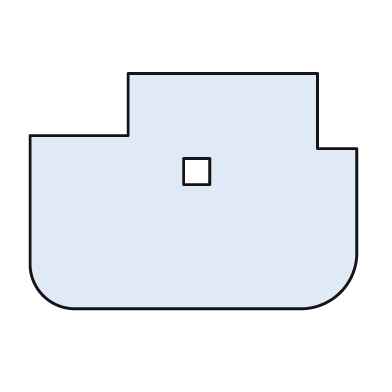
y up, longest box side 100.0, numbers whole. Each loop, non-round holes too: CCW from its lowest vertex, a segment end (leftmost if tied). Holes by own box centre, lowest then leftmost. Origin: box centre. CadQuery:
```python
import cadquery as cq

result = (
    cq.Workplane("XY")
    .moveTo(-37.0, -36.0)
    .lineTo(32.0, -36.0)
    .threePointArc((45.0, -31.0), (50.0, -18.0))
    .lineTo(50.0, 13.0)
    .lineTo(38.0, 13.0)
    .lineTo(38.0, 36.0)
    .lineTo(-20.0, 36.0)
    .lineTo(-20.0, 17.0)
    .lineTo(-50.0, 17.0)
    .lineTo(-50.0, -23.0)
    .threePointArc((-46.0, -32.0), (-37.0, -36.0))
    .close()
    .moveTo(-3.0, 2.0)
    .lineTo(5.0, 2.0)
    .lineTo(5.0, 10.0)
    .lineTo(-3.0, 10.0)
    .close()
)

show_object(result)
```